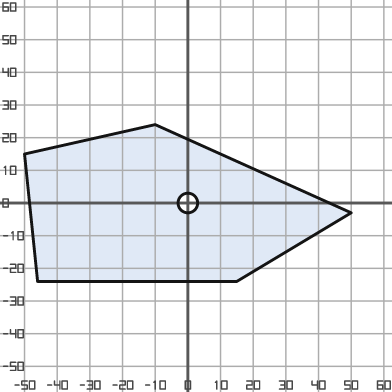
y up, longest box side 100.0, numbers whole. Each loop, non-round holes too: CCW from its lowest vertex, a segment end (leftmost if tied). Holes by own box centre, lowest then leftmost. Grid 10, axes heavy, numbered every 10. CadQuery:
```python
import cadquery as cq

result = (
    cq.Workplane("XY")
    .moveTo(-46.0, -24.0)
    .lineTo(15.0, -24.0)
    .lineTo(50.0, -3.0)
    .lineTo(-10.0, 24.0)
    .lineTo(-50.0, 15.0)
    .close()
    .moveTo(0.0, 0.0)
    .circle(3.0)
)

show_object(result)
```